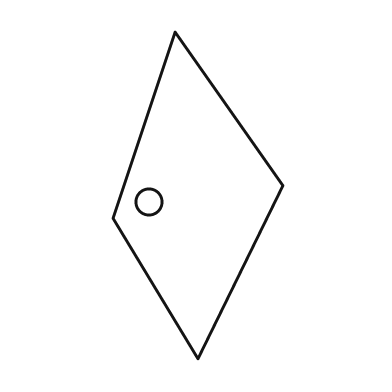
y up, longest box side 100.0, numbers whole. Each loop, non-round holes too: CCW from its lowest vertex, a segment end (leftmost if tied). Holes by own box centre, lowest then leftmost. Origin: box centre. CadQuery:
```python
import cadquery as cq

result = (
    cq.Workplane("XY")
    .moveTo(0.0, -50.0)
    .lineTo(26.0, 3.0)
    .lineTo(-7.0, 50.0)
    .lineTo(-26.0, -7.0)
    .close()
    .moveTo(-15.0, -2.0)
    .circle(4.0)
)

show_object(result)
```